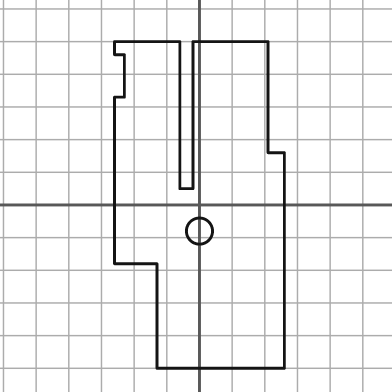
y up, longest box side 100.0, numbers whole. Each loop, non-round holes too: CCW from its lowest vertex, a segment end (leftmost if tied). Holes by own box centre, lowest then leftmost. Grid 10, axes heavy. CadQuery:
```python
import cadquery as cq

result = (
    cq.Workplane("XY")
    .moveTo(-13.0, -50.0)
    .lineTo(26.0, -50.0)
    .lineTo(26.0, 16.0)
    .lineTo(21.0, 16.0)
    .lineTo(21.0, 50.0)
    .lineTo(-2.0, 50.0)
    .lineTo(-2.0, 5.0)
    .lineTo(-6.0, 5.0)
    .lineTo(-6.0, 50.0)
    .lineTo(-26.0, 50.0)
    .lineTo(-26.0, 46.0)
    .lineTo(-23.0, 46.0)
    .lineTo(-23.0, 33.0)
    .lineTo(-26.0, 33.0)
    .lineTo(-26.0, -18.0)
    .lineTo(-13.0, -18.0)
    .close()
    .moveTo(0.0, -8.0)
    .circle(4.0)
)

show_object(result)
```